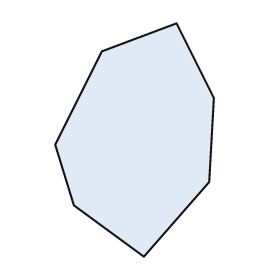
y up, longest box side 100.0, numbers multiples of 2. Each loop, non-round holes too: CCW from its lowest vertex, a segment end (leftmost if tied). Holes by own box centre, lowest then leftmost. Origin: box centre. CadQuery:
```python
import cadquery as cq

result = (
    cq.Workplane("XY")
    .moveTo(4.0, -50.0)
    .lineTo(32.0, -18.0)
    .lineTo(34.0, 18.0)
    .lineTo(18.0, 50.0)
    .lineTo(-14.0, 38.0)
    .lineTo(-34.0, -2.0)
    .lineTo(-26.0, -28.0)
    .close()
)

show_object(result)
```